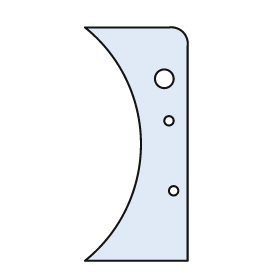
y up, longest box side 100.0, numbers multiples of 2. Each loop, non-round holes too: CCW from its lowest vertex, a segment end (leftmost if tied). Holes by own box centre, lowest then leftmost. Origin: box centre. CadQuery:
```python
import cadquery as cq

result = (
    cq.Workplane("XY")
    .moveTo(-22.0, -50.0)
    .lineTo(22.0, -50.0)
    .lineTo(22.0, 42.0)
    .threePointArc((20.0, 48.0), (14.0, 50.0))
    .lineTo(-22.0, 50.0)
    .threePointArc((2.0, 0.0), (-22.0, -50.0))
    .close()
    .moveTo(16.0, -20.0)
    .circle(2.0)
    .moveTo(14.0, 10.0)
    .circle(2.0)
    .moveTo(12.0, 28.0)
    .circle(4.0)
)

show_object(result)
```